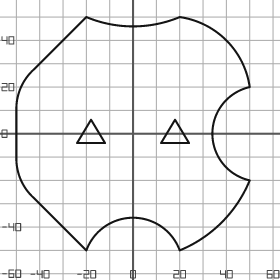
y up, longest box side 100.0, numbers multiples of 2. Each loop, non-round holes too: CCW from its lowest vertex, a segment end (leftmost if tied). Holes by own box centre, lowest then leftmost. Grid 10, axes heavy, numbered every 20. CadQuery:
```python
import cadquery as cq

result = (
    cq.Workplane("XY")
    .moveTo(-20.0, -50.0)
    .threePointArc((0.0, -36.0), (20.0, -50.0))
    .threePointArc((38.0, -38.0), (50.0, -20.0))
    .threePointArc((34.0, 0.0), (50.0, 20.0))
    .threePointArc((40.0, 40.0), (20.0, 50.0))
    .threePointArc((0.0, 46.0), (-20.0, 50.0))
    .lineTo(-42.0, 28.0)
    .threePointArc((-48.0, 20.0), (-50.0, 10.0))
    .lineTo(-50.0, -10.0)
    .threePointArc((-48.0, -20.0), (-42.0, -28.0))
    .close()
    .moveTo(-24.0, -4.0)
    .lineTo(-12.0, -4.0)
    .lineTo(-18.0, 6.0)
    .close()
    .moveTo(12.0, -4.0)
    .lineTo(24.0, -4.0)
    .lineTo(18.0, 6.0)
    .close()
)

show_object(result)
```